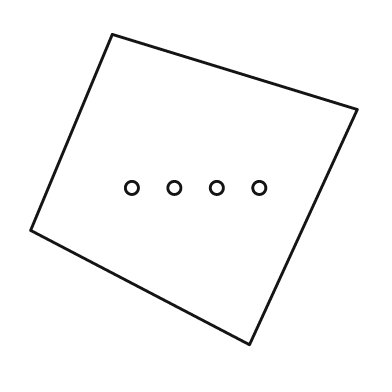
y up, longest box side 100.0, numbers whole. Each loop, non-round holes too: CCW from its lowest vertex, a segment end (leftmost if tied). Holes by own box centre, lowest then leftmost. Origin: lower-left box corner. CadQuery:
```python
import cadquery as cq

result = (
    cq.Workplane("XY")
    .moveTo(67.0, 0.0)
    .lineTo(100.0, 72.0)
    .lineTo(25.0, 95.0)
    .lineTo(0.0, 35.0)
    .close()
    .moveTo(31.0, 48.0)
    .circle(2.0)
    .moveTo(44.0, 48.0)
    .circle(2.0)
    .moveTo(57.0, 48.0)
    .circle(2.0)
    .moveTo(70.0, 48.0)
    .circle(2.0)
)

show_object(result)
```